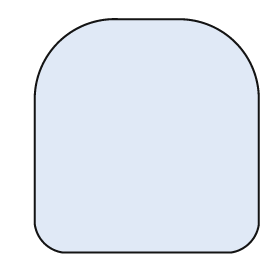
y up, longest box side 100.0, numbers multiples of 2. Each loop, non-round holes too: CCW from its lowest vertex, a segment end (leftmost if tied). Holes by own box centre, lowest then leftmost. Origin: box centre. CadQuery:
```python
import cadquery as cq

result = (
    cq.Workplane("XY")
    .moveTo(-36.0, -50.0)
    .lineTo(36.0, -50.0)
    .threePointArc((44.0, -46.0), (48.0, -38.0))
    .lineTo(48.0, 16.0)
    .threePointArc((38.0, 40.0), (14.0, 50.0))
    .lineTo(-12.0, 50.0)
    .threePointArc((-38.0, 40.0), (-48.0, 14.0))
    .lineTo(-48.0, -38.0)
    .threePointArc((-44.0, -46.0), (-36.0, -50.0))
    .close()
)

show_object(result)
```